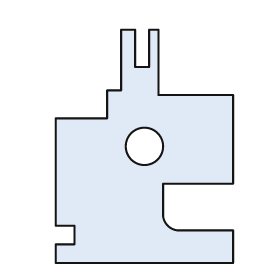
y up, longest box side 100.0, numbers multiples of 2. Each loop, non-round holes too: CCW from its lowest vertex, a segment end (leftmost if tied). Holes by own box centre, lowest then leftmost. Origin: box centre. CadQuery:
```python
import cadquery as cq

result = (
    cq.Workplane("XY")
    .moveTo(-38.0, -50.0)
    .lineTo(38.0, -50.0)
    .lineTo(38.0, -36.0)
    .lineTo(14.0, -36.0)
    .threePointArc((10.0, -34.0), (8.0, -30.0))
    .lineTo(8.0, -16.0)
    .lineTo(38.0, -16.0)
    .lineTo(38.0, 22.0)
    .lineTo(6.0, 22.0)
    .lineTo(6.0, 50.0)
    .lineTo(2.0, 50.0)
    .lineTo(2.0, 34.0)
    .lineTo(-4.0, 34.0)
    .lineTo(-4.0, 50.0)
    .lineTo(-10.0, 50.0)
    .lineTo(-10.0, 24.0)
    .lineTo(-16.0, 24.0)
    .lineTo(-16.0, 12.0)
    .lineTo(-38.0, 12.0)
    .lineTo(-38.0, -34.0)
    .lineTo(-30.0, -34.0)
    .lineTo(-30.0, -42.0)
    .lineTo(-38.0, -42.0)
    .close()
    .moveTo(0.0, 0.0)
    .circle(8.0)
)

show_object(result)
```